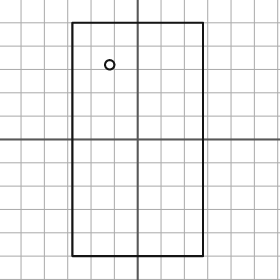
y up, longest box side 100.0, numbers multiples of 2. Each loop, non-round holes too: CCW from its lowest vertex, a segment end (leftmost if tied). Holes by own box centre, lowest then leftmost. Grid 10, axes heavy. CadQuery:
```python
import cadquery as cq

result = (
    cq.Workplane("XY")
    .moveTo(-28.0, -50.0)
    .lineTo(28.0, -50.0)
    .lineTo(28.0, 50.0)
    .lineTo(-28.0, 50.0)
    .close()
    .moveTo(-12.0, 32.0)
    .circle(2.0)
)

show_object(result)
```